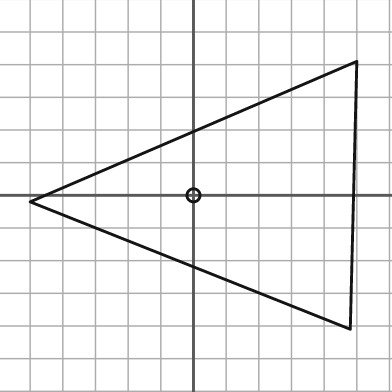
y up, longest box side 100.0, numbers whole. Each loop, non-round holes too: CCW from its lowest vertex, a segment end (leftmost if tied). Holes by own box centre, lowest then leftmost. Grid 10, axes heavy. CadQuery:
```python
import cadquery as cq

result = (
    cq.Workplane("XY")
    .moveTo(48.0, -41.0)
    .lineTo(50.0, 41.0)
    .lineTo(-50.0, -2.0)
    .close()
    .moveTo(0.0, 0.0)
    .circle(2.0)
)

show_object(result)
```